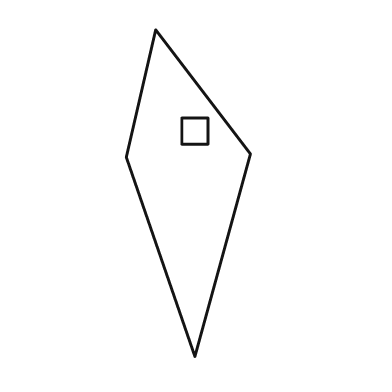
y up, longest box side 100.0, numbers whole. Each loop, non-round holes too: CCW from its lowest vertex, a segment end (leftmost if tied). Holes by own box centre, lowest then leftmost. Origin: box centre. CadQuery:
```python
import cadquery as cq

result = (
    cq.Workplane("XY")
    .moveTo(2.0, -50.0)
    .lineTo(19.0, 12.0)
    .lineTo(-10.0, 50.0)
    .lineTo(-19.0, 11.0)
    .close()
    .moveTo(-2.0, 15.0)
    .lineTo(6.0, 15.0)
    .lineTo(6.0, 23.0)
    .lineTo(-2.0, 23.0)
    .close()
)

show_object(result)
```